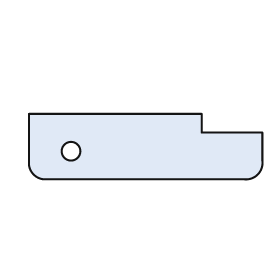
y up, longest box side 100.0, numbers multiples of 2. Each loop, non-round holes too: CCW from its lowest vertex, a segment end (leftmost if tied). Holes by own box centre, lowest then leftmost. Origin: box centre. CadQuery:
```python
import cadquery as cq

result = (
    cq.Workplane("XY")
    .moveTo(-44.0, -14.0)
    .lineTo(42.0, -14.0)
    .threePointArc((48.0, -12.0), (50.0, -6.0))
    .lineTo(50.0, 6.0)
    .lineTo(24.0, 6.0)
    .lineTo(24.0, 14.0)
    .lineTo(-50.0, 14.0)
    .lineTo(-50.0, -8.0)
    .threePointArc((-48.0, -12.0), (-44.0, -14.0))
    .close()
    .moveTo(-32.0, -2.0)
    .circle(4.0)
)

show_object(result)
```